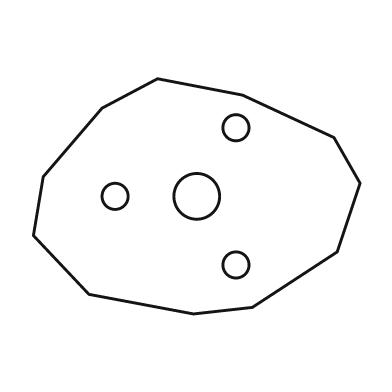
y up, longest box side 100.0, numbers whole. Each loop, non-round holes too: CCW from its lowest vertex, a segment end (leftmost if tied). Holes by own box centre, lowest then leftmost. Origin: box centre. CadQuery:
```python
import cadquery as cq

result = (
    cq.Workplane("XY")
    .moveTo(-1.0, -36.0)
    .lineTo(17.0, -34.0)
    .lineTo(43.0, -17.0)
    .lineTo(50.0, 4.0)
    .lineTo(42.0, 18.0)
    .lineTo(14.0, 31.0)
    .lineTo(-12.0, 36.0)
    .lineTo(-29.0, 27.0)
    .lineTo(-47.0, 6.0)
    .lineTo(-50.0, -12.0)
    .lineTo(-33.0, -30.0)
    .close()
    .moveTo(12.0, -21.0)
    .circle(4.0)
    .moveTo(-25.0, 0.0)
    .circle(4.0)
    .moveTo(0.0, 0.0)
    .circle(7.0)
    .moveTo(12.0, 21.0)
    .circle(4.0)
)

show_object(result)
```